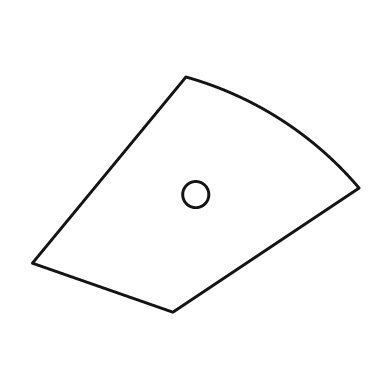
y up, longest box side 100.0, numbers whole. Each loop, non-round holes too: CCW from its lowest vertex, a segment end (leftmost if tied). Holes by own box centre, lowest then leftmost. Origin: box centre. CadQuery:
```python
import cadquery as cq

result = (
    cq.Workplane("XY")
    .moveTo(-7.0, -36.0)
    .lineTo(50.0, 2.0)
    .threePointArc((26.0, 23.0), (-3.0, 36.0))
    .lineTo(-50.0, -21.0)
    .close()
    .moveTo(0.0, 0.0)
    .circle(4.0)
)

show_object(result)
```